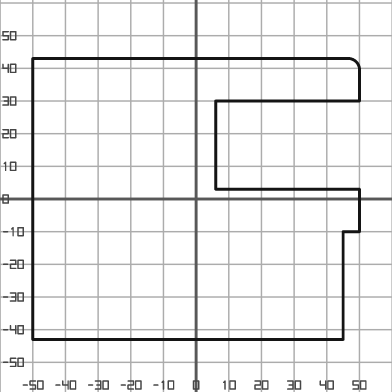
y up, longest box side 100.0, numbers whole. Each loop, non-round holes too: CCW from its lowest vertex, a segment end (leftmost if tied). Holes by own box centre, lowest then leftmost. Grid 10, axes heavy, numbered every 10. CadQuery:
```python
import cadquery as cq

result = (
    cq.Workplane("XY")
    .moveTo(-50.0, -43.0)
    .lineTo(45.0, -43.0)
    .lineTo(45.0, -10.0)
    .lineTo(50.0, -10.0)
    .lineTo(50.0, 3.0)
    .lineTo(6.0, 3.0)
    .lineTo(6.0, 30.0)
    .lineTo(50.0, 30.0)
    .lineTo(50.0, 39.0)
    .threePointArc((49.0, 42.0), (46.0, 43.0))
    .lineTo(-50.0, 43.0)
    .close()
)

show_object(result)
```